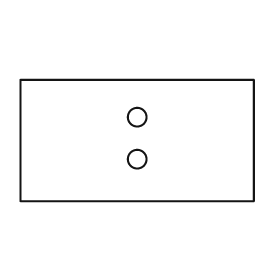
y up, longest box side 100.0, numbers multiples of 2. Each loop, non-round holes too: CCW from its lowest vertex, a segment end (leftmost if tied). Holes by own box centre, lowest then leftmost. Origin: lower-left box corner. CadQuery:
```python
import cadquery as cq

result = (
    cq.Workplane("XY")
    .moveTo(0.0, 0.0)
    .lineTo(100.0, 0.0)
    .lineTo(100.0, 52.0)
    .lineTo(0.0, 52.0)
    .close()
    .moveTo(50.0, 18.0)
    .circle(4.0)
    .moveTo(50.0, 36.0)
    .circle(4.0)
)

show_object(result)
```